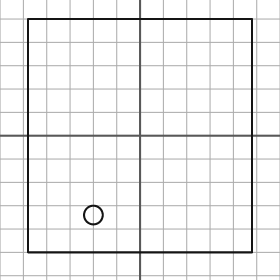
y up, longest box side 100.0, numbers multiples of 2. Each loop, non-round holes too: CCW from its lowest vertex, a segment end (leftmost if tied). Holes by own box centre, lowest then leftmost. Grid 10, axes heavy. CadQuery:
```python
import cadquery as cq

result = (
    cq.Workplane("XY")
    .moveTo(-48.0, -50.0)
    .lineTo(48.0, -50.0)
    .lineTo(48.0, 50.0)
    .lineTo(-48.0, 50.0)
    .close()
    .moveTo(-20.0, -34.0)
    .circle(4.0)
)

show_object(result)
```